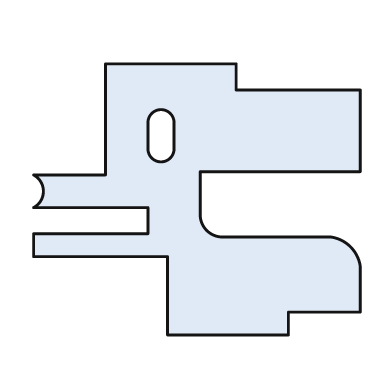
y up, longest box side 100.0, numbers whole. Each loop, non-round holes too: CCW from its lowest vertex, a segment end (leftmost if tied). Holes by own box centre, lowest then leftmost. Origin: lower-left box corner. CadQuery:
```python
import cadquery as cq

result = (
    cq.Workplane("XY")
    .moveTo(41.0, 0.0)
    .lineTo(78.0, 0.0)
    .lineTo(78.0, 7.0)
    .lineTo(100.0, 7.0)
    .lineTo(100.0, 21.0)
    .threePointArc((97.0, 27.0), (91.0, 30.0))
    .lineTo(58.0, 30.0)
    .threePointArc((53.0, 32.0), (51.0, 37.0))
    .lineTo(51.0, 50.0)
    .lineTo(100.0, 50.0)
    .lineTo(100.0, 75.0)
    .lineTo(62.0, 75.0)
    .lineTo(62.0, 83.0)
    .lineTo(22.0, 83.0)
    .lineTo(22.0, 49.0)
    .lineTo(0.0, 49.0)
    .threePointArc((3.0, 44.0), (0.0, 39.0))
    .lineTo(35.0, 39.0)
    .lineTo(35.0, 31.0)
    .lineTo(0.0, 31.0)
    .lineTo(0.0, 24.0)
    .lineTo(41.0, 24.0)
    .close()
    .moveTo(35.0, 57.0)
    .threePointArc((39.0, 53.0), (43.0, 57.0))
    .lineTo(43.0, 65.0)
    .threePointArc((39.0, 69.0), (35.0, 65.0))
    .close()
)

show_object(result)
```